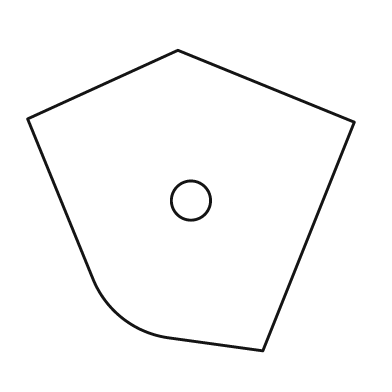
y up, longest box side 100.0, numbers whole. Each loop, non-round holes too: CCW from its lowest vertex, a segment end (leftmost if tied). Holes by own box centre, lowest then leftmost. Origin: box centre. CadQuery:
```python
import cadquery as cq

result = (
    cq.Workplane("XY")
    .moveTo(22.0, -46.0)
    .lineTo(50.0, 24.0)
    .lineTo(-4.0, 46.0)
    .lineTo(-50.0, 25.0)
    .lineTo(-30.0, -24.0)
    .threePointArc((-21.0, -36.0), (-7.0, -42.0))
    .close()
    .moveTo(0.0, 0.0)
    .circle(6.0)
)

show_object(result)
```